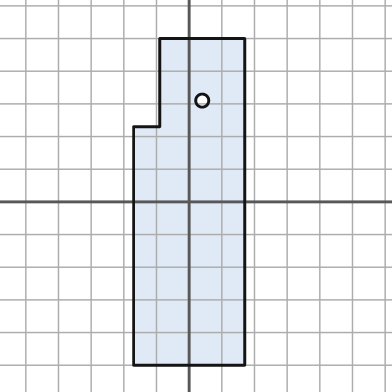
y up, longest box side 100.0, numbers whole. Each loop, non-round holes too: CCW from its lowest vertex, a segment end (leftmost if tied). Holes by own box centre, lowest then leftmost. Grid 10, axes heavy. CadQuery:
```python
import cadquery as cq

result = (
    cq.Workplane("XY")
    .moveTo(-17.0, -50.0)
    .lineTo(17.0, -50.0)
    .lineTo(17.0, 50.0)
    .lineTo(-9.0, 50.0)
    .lineTo(-9.0, 23.0)
    .lineTo(-17.0, 23.0)
    .close()
    .moveTo(4.0, 31.0)
    .circle(2.0)
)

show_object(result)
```